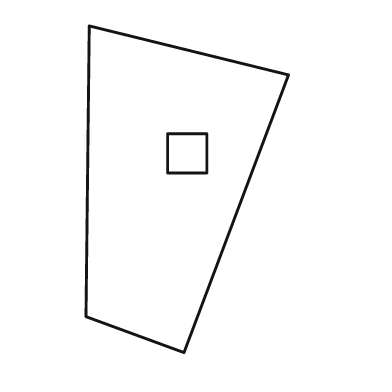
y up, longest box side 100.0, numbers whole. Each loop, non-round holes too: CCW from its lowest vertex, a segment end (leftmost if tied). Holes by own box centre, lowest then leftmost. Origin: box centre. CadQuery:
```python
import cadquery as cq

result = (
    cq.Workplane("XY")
    .moveTo(-1.0, -50.0)
    .lineTo(31.0, 35.0)
    .lineTo(-30.0, 50.0)
    .lineTo(-31.0, -39.0)
    .close()
    .moveTo(-6.0, 5.0)
    .lineTo(6.0, 5.0)
    .lineTo(6.0, 17.0)
    .lineTo(-6.0, 17.0)
    .close()
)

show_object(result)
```